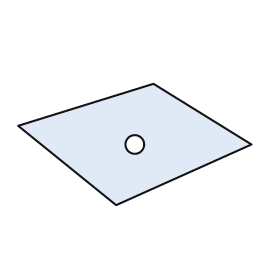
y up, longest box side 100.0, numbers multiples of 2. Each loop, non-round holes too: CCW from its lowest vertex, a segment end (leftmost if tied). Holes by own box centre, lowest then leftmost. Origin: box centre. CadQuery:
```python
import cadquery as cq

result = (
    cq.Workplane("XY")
    .moveTo(-8.0, -26.0)
    .lineTo(50.0, 0.0)
    .lineTo(8.0, 26.0)
    .lineTo(-50.0, 8.0)
    .close()
    .moveTo(0.0, 0.0)
    .circle(4.0)
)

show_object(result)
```